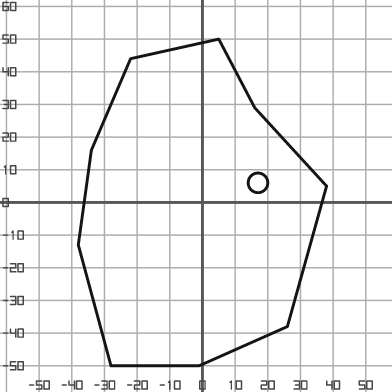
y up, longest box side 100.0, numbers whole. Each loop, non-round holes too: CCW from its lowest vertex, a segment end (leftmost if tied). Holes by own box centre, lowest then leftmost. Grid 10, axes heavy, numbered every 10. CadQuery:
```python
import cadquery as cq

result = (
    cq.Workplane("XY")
    .moveTo(-28.0, -50.0)
    .lineTo(-1.0, -50.0)
    .lineTo(26.0, -38.0)
    .lineTo(38.0, 5.0)
    .lineTo(16.0, 29.0)
    .lineTo(5.0, 50.0)
    .lineTo(-22.0, 44.0)
    .lineTo(-34.0, 16.0)
    .lineTo(-38.0, -13.0)
    .close()
    .moveTo(17.0, 6.0)
    .circle(3.0)
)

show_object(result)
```